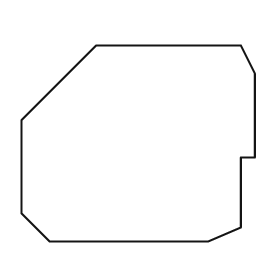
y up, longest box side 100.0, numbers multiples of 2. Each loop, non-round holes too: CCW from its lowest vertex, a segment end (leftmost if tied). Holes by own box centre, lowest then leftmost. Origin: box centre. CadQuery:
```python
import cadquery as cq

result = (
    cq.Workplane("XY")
    .moveTo(-38.0, -42.0)
    .lineTo(30.0, -42.0)
    .lineTo(44.0, -36.0)
    .lineTo(44.0, -6.0)
    .lineTo(50.0, -6.0)
    .lineTo(50.0, 30.0)
    .lineTo(44.0, 42.0)
    .lineTo(-18.0, 42.0)
    .lineTo(-50.0, 10.0)
    .lineTo(-50.0, -30.0)
    .close()
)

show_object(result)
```